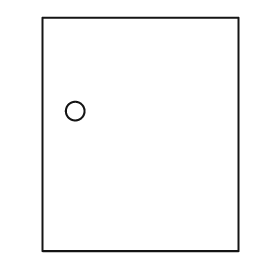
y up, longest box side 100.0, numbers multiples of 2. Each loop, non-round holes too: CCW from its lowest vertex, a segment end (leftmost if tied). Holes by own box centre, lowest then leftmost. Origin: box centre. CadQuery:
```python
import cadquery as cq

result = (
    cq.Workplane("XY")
    .moveTo(-42.0, -50.0)
    .lineTo(42.0, -50.0)
    .lineTo(42.0, 50.0)
    .lineTo(-42.0, 50.0)
    .close()
    .moveTo(-28.0, 10.0)
    .circle(4.0)
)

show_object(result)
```